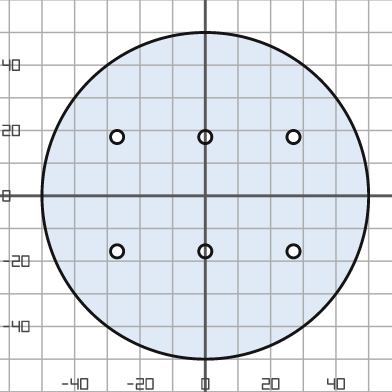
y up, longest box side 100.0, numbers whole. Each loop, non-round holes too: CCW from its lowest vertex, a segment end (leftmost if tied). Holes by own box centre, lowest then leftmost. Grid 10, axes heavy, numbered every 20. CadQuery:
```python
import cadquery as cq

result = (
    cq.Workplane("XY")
    .moveTo(0.0, 0.0)
    .circle(50.0)
    .moveTo(-27.0, -17.0)
    .circle(2.0)
    .moveTo(0.0, -17.0)
    .circle(2.0)
    .moveTo(27.0, -17.0)
    .circle(2.0)
    .moveTo(-27.0, 18.0)
    .circle(2.0)
    .moveTo(0.0, 18.0)
    .circle(2.0)
    .moveTo(27.0, 18.0)
    .circle(2.0)
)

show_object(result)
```